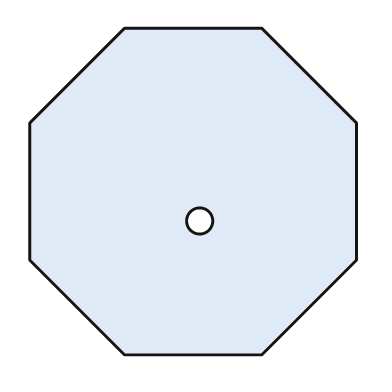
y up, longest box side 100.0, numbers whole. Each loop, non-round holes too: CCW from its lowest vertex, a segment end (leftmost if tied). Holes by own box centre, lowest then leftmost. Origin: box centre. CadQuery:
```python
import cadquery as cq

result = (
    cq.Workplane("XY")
    .moveTo(-21.0, -50.0)
    .lineTo(21.0, -50.0)
    .lineTo(50.0, -21.0)
    .lineTo(50.0, 21.0)
    .lineTo(21.0, 50.0)
    .lineTo(-21.0, 50.0)
    .lineTo(-50.0, 21.0)
    .lineTo(-50.0, -21.0)
    .close()
    .moveTo(2.0, -9.0)
    .circle(4.0)
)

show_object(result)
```